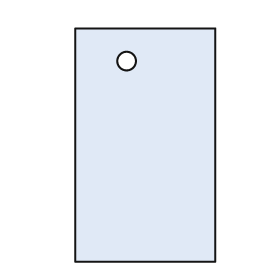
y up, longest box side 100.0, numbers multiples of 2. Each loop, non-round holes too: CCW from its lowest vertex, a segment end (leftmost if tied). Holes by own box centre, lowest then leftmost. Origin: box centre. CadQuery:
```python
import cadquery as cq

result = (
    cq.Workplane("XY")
    .moveTo(-30.0, -50.0)
    .lineTo(30.0, -50.0)
    .lineTo(30.0, 50.0)
    .lineTo(-30.0, 50.0)
    .close()
    .moveTo(-8.0, 36.0)
    .circle(4.0)
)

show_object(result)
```